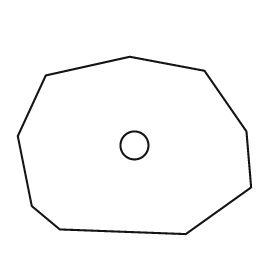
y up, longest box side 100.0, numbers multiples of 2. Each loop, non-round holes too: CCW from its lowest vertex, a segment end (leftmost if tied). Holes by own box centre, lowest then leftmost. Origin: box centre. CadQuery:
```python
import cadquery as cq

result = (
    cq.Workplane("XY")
    .moveTo(22.0, -38.0)
    .lineTo(50.0, -18.0)
    .lineTo(48.0, 6.0)
    .lineTo(30.0, 32.0)
    .lineTo(-2.0, 38.0)
    .lineTo(-38.0, 30.0)
    .lineTo(-50.0, 4.0)
    .lineTo(-44.0, -26.0)
    .lineTo(-32.0, -36.0)
    .close()
    .moveTo(0.0, 0.0)
    .circle(6.0)
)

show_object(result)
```